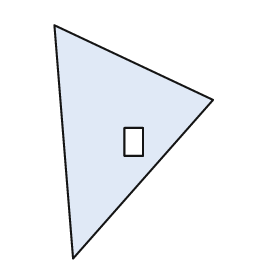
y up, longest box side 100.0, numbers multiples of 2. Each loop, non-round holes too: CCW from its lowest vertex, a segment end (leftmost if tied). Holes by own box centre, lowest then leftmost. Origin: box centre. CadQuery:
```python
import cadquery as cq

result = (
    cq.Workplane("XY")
    .moveTo(-26.0, -50.0)
    .lineTo(34.0, 18.0)
    .lineTo(-34.0, 50.0)
    .close()
    .moveTo(-4.0, -6.0)
    .lineTo(4.0, -6.0)
    .lineTo(4.0, 6.0)
    .lineTo(-4.0, 6.0)
    .close()
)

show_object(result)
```